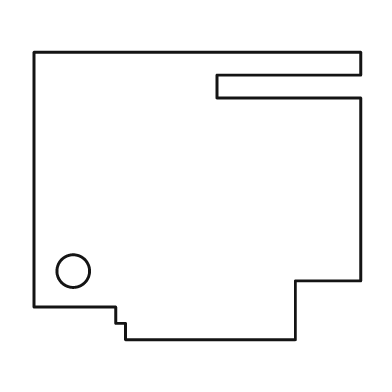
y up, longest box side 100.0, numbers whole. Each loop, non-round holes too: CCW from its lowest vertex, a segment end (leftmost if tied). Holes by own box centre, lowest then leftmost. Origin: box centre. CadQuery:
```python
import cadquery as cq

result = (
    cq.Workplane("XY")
    .moveTo(-22.0, -44.0)
    .lineTo(30.0, -44.0)
    .lineTo(30.0, -26.0)
    .lineTo(50.0, -26.0)
    .lineTo(50.0, 30.0)
    .lineTo(6.0, 30.0)
    .lineTo(6.0, 37.0)
    .lineTo(50.0, 37.0)
    .lineTo(50.0, 44.0)
    .lineTo(-50.0, 44.0)
    .lineTo(-50.0, -34.0)
    .lineTo(-25.0, -34.0)
    .lineTo(-25.0, -39.0)
    .lineTo(-22.0, -39.0)
    .close()
    .moveTo(-38.0, -23.0)
    .circle(5.0)
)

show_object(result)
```